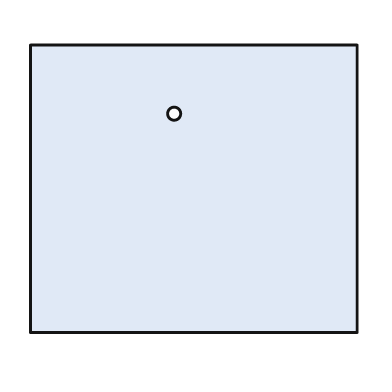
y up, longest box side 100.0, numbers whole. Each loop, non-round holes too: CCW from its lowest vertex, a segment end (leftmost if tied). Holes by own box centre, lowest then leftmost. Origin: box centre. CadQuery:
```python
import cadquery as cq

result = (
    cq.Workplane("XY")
    .moveTo(-50.0, -44.0)
    .lineTo(50.0, -44.0)
    .lineTo(50.0, 44.0)
    .lineTo(-50.0, 44.0)
    .close()
    .moveTo(-6.0, 23.0)
    .circle(2.0)
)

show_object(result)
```